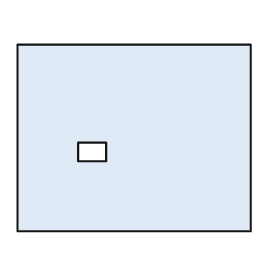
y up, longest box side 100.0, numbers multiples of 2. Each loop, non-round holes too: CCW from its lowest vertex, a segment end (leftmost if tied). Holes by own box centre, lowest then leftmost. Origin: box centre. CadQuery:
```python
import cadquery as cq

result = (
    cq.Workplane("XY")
    .moveTo(-50.0, -40.0)
    .lineTo(50.0, -40.0)
    .lineTo(50.0, 40.0)
    .lineTo(-50.0, 40.0)
    .close()
    .moveTo(-24.0, -10.0)
    .lineTo(-12.0, -10.0)
    .lineTo(-12.0, -2.0)
    .lineTo(-24.0, -2.0)
    .close()
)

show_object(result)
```